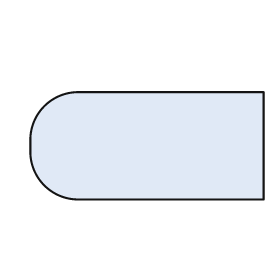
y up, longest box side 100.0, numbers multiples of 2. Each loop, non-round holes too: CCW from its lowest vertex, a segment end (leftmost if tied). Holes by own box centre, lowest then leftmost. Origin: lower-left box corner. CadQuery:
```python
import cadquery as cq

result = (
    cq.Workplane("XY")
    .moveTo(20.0, 0.0)
    .lineTo(100.0, 0.0)
    .lineTo(100.0, 46.0)
    .lineTo(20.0, 46.0)
    .threePointArc((6.0, 40.0), (0.0, 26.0))
    .lineTo(0.0, 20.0)
    .threePointArc((6.0, 6.0), (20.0, 0.0))
    .close()
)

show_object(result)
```